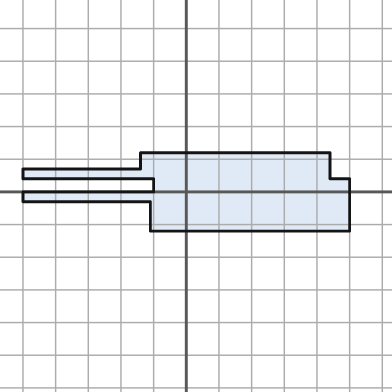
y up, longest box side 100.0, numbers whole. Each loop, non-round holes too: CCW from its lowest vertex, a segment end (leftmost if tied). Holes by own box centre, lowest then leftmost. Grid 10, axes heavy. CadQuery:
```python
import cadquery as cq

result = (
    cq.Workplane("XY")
    .moveTo(-11.0, -12.0)
    .lineTo(50.0, -12.0)
    .lineTo(50.0, 4.0)
    .lineTo(44.0, 4.0)
    .lineTo(44.0, 12.0)
    .lineTo(-14.0, 12.0)
    .lineTo(-14.0, 7.0)
    .lineTo(-50.0, 7.0)
    .lineTo(-50.0, 4.0)
    .lineTo(-10.0, 4.0)
    .lineTo(-10.0, 0.0)
    .lineTo(-50.0, 0.0)
    .lineTo(-50.0, -3.0)
    .lineTo(-11.0, -3.0)
    .close()
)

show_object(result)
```